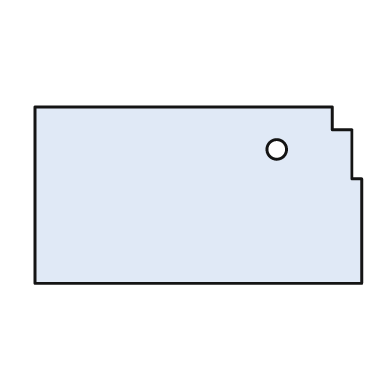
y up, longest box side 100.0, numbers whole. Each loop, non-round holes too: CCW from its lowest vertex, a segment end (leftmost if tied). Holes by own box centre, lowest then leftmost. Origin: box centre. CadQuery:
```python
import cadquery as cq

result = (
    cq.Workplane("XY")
    .moveTo(-50.0, -27.0)
    .lineTo(50.0, -27.0)
    .lineTo(50.0, 5.0)
    .lineTo(47.0, 5.0)
    .lineTo(47.0, 20.0)
    .lineTo(41.0, 20.0)
    .lineTo(41.0, 27.0)
    .lineTo(-50.0, 27.0)
    .close()
    .moveTo(24.0, 14.0)
    .circle(3.0)
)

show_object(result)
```